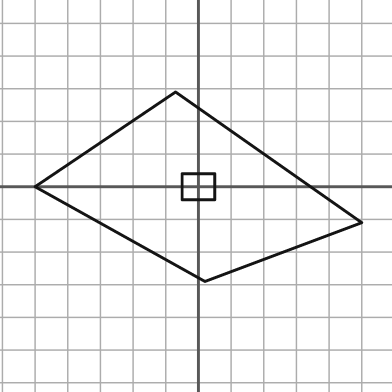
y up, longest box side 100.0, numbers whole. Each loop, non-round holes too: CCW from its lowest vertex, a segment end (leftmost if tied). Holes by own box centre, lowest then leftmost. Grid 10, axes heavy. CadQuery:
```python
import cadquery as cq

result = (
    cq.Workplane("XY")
    .moveTo(2.0, -29.0)
    .lineTo(50.0, -11.0)
    .lineTo(-7.0, 29.0)
    .lineTo(-50.0, 0.0)
    .close()
    .moveTo(-5.0, -4.0)
    .lineTo(5.0, -4.0)
    .lineTo(5.0, 4.0)
    .lineTo(-5.0, 4.0)
    .close()
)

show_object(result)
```